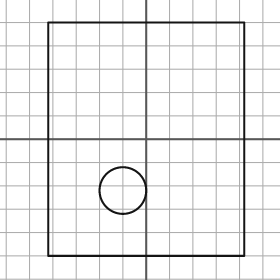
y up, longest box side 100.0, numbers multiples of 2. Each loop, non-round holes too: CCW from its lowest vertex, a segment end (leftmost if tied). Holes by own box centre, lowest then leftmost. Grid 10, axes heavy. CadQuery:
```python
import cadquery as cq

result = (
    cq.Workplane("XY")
    .moveTo(-42.0, -50.0)
    .lineTo(42.0, -50.0)
    .lineTo(42.0, 50.0)
    .lineTo(-42.0, 50.0)
    .close()
    .moveTo(-10.0, -22.0)
    .circle(10.0)
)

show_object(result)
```